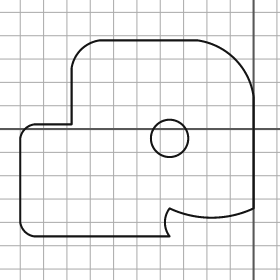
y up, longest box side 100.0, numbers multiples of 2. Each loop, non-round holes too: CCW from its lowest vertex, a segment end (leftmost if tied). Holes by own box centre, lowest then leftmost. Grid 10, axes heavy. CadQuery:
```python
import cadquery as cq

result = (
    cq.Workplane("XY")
    .moveTo(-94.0, -46.0)
    .lineTo(-36.0, -46.0)
    .threePointArc((-38.0, -40.0), (-36.0, -34.0))
    .threePointArc((-18.0, -38.0), (0.0, -34.0))
    .lineTo(0.0, 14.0)
    .threePointArc((-8.0, 30.0), (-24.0, 38.0))
    .lineTo(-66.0, 38.0)
    .threePointArc((-74.0, 34.0), (-78.0, 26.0))
    .lineTo(-78.0, 2.0)
    .lineTo(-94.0, 2.0)
    .threePointArc((-98.0, 0.0), (-100.0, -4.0))
    .lineTo(-100.0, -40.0)
    .threePointArc((-98.0, -44.0), (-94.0, -46.0))
    .close()
    .moveTo(-36.0, -4.0)
    .circle(8.0)
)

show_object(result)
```